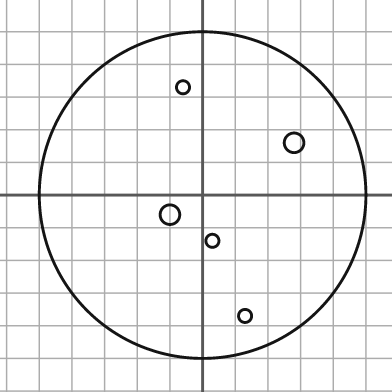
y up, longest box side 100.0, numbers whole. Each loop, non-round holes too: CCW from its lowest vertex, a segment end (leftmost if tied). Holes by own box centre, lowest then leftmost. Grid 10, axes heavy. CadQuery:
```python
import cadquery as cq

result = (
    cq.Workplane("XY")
    .moveTo(0.0, 0.0)
    .circle(50.0)
    .moveTo(13.0, -37.0)
    .circle(2.0)
    .moveTo(3.0, -14.0)
    .circle(2.0)
    .moveTo(-10.0, -6.0)
    .circle(3.0)
    .moveTo(28.0, 16.0)
    .circle(3.0)
    .moveTo(-6.0, 33.0)
    .circle(2.0)
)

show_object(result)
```